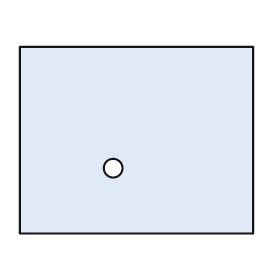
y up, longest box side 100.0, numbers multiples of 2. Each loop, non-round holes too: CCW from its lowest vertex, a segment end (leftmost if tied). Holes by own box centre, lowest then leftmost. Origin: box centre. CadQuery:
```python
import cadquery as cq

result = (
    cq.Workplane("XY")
    .moveTo(-50.0, -40.0)
    .lineTo(50.0, -40.0)
    .lineTo(50.0, 40.0)
    .lineTo(-50.0, 40.0)
    .close()
    .moveTo(-10.0, -12.0)
    .circle(4.0)
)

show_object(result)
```